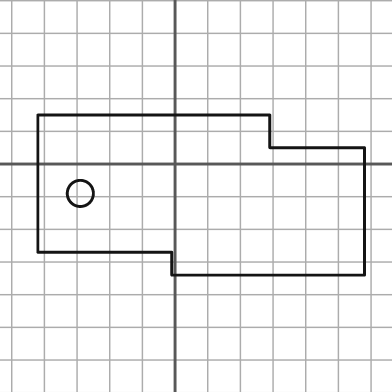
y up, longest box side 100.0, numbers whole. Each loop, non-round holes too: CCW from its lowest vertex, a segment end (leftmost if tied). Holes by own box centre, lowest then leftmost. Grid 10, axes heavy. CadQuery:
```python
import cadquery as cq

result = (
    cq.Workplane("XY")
    .moveTo(-1.0, -34.0)
    .lineTo(58.0, -34.0)
    .lineTo(58.0, 5.0)
    .lineTo(29.0, 5.0)
    .lineTo(29.0, 15.0)
    .lineTo(-42.0, 15.0)
    .lineTo(-42.0, -27.0)
    .lineTo(-1.0, -27.0)
    .close()
    .moveTo(-29.0, -9.0)
    .circle(4.0)
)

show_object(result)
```